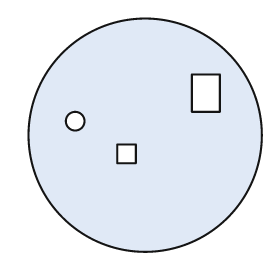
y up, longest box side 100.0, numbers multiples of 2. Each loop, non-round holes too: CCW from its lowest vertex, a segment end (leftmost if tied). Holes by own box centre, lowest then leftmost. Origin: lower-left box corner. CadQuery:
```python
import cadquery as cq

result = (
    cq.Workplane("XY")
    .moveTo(50.0, 50.0)
    .circle(50.0)
    .moveTo(38.0, 38.0)
    .lineTo(46.0, 38.0)
    .lineTo(46.0, 46.0)
    .lineTo(38.0, 46.0)
    .close()
    .moveTo(20.0, 56.0)
    .circle(4.0)
    .moveTo(70.0, 60.0)
    .lineTo(82.0, 60.0)
    .lineTo(82.0, 76.0)
    .lineTo(70.0, 76.0)
    .close()
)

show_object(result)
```